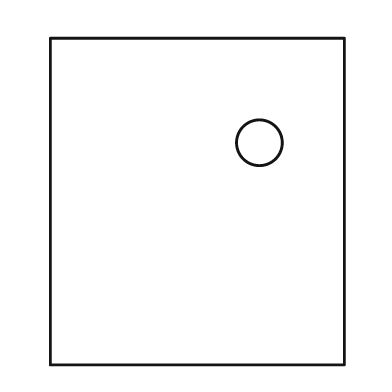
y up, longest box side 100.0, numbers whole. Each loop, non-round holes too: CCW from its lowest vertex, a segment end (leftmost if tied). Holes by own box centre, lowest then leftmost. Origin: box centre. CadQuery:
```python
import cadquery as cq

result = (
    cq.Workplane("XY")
    .moveTo(-45.0, -50.0)
    .lineTo(45.0, -50.0)
    .lineTo(45.0, 50.0)
    .lineTo(-45.0, 50.0)
    .close()
    .moveTo(19.0, 18.0)
    .circle(7.0)
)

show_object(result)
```